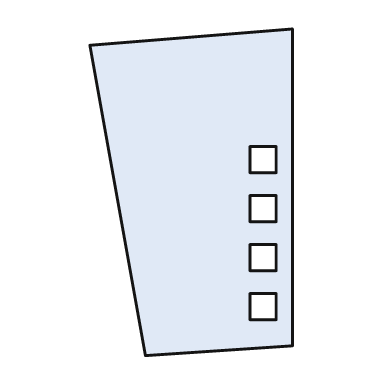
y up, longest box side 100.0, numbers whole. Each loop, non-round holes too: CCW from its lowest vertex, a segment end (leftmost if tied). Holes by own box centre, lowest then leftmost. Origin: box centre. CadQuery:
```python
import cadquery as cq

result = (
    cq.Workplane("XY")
    .moveTo(-14.0, -50.0)
    .lineTo(31.0, -47.0)
    .lineTo(31.0, 50.0)
    .lineTo(-31.0, 45.0)
    .close()
    .moveTo(18.0, -39.0)
    .lineTo(26.0, -39.0)
    .lineTo(26.0, -31.0)
    .lineTo(18.0, -31.0)
    .close()
    .moveTo(18.0, -24.0)
    .lineTo(26.0, -24.0)
    .lineTo(26.0, -16.0)
    .lineTo(18.0, -16.0)
    .close()
    .moveTo(18.0, -9.0)
    .lineTo(26.0, -9.0)
    .lineTo(26.0, -1.0)
    .lineTo(18.0, -1.0)
    .close()
    .moveTo(18.0, 6.0)
    .lineTo(26.0, 6.0)
    .lineTo(26.0, 14.0)
    .lineTo(18.0, 14.0)
    .close()
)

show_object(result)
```